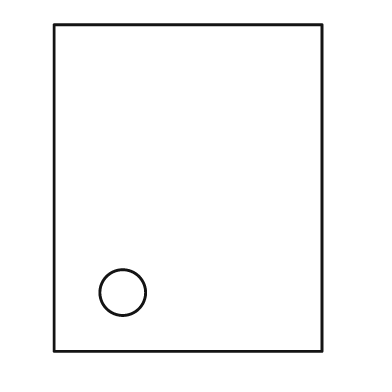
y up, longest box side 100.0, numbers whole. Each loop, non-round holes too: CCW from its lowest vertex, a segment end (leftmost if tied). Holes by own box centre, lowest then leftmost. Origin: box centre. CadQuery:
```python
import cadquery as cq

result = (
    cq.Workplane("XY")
    .moveTo(-41.0, -50.0)
    .lineTo(41.0, -50.0)
    .lineTo(41.0, 50.0)
    .lineTo(-41.0, 50.0)
    .close()
    .moveTo(-20.0, -32.0)
    .circle(7.0)
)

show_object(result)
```